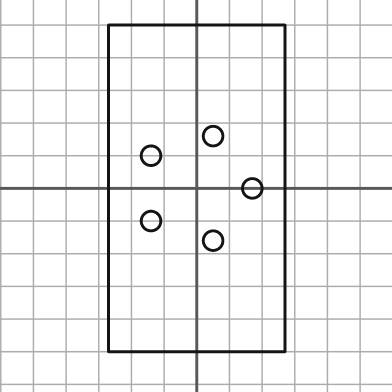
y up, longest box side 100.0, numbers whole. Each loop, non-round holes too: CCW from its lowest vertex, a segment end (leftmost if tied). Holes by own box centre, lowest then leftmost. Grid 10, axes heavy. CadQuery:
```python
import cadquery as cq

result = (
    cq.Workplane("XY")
    .moveTo(-27.0, -50.0)
    .lineTo(27.0, -50.0)
    .lineTo(27.0, 50.0)
    .lineTo(-27.0, 50.0)
    .close()
    .moveTo(5.0, -16.0)
    .circle(3.0)
    .moveTo(-14.0, -10.0)
    .circle(3.0)
    .moveTo(17.0, 0.0)
    .circle(3.0)
    .moveTo(-14.0, 10.0)
    .circle(3.0)
    .moveTo(5.0, 16.0)
    .circle(3.0)
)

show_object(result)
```